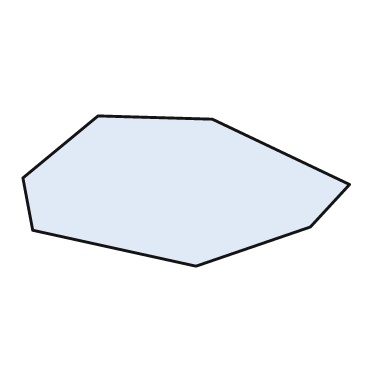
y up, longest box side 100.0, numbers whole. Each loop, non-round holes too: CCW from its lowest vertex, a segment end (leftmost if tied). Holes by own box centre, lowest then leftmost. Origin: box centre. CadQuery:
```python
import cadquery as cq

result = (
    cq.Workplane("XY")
    .moveTo(3.0, -23.0)
    .lineTo(38.0, -11.0)
    .lineTo(50.0, 2.0)
    .lineTo(8.0, 22.0)
    .lineTo(-27.0, 23.0)
    .lineTo(-50.0, 4.0)
    .lineTo(-47.0, -12.0)
    .close()
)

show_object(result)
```